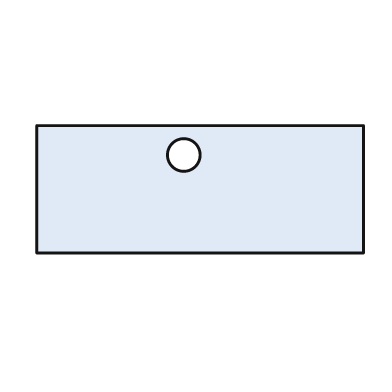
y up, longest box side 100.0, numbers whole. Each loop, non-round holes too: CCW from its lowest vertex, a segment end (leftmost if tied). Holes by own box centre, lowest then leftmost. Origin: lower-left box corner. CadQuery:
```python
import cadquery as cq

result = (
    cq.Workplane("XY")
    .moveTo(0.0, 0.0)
    .lineTo(100.0, 0.0)
    .lineTo(100.0, 39.0)
    .lineTo(0.0, 39.0)
    .close()
    .moveTo(45.0, 30.0)
    .circle(5.0)
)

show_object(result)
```